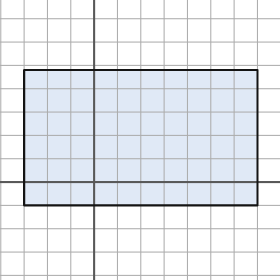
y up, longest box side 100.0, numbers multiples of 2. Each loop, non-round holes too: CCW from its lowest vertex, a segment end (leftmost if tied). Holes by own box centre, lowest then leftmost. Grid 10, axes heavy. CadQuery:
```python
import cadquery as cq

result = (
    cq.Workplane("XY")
    .moveTo(-30.0, -10.0)
    .lineTo(70.0, -10.0)
    .lineTo(70.0, 48.0)
    .lineTo(-30.0, 48.0)
    .close()
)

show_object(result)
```